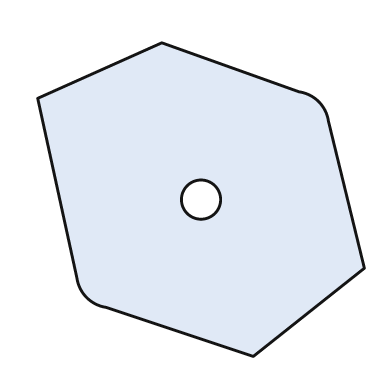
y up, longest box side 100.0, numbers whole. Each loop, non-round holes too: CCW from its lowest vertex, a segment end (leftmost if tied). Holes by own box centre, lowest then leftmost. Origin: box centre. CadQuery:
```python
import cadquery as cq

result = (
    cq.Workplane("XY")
    .moveTo(16.0, -48.0)
    .lineTo(50.0, -21.0)
    .lineTo(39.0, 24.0)
    .threePointArc((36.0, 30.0), (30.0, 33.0))
    .lineTo(-12.0, 48.0)
    .lineTo(-50.0, 31.0)
    .lineTo(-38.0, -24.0)
    .threePointArc((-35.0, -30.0), (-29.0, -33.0))
    .close()
    .moveTo(0.0, 0.0)
    .circle(6.0)
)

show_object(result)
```